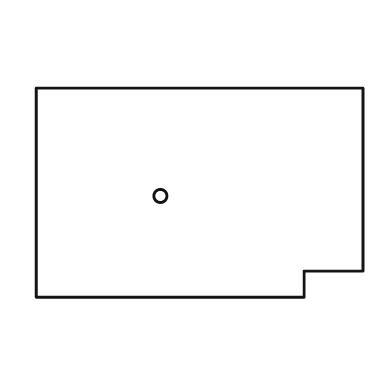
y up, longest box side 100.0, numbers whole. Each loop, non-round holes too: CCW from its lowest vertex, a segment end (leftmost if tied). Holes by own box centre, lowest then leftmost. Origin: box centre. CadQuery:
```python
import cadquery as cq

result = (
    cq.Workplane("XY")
    .moveTo(-50.0, -32.0)
    .lineTo(32.0, -32.0)
    .lineTo(32.0, -24.0)
    .lineTo(50.0, -24.0)
    .lineTo(50.0, 32.0)
    .lineTo(-50.0, 32.0)
    .close()
    .moveTo(-12.0, -1.0)
    .circle(2.0)
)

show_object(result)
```